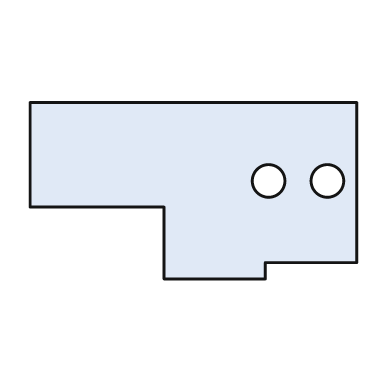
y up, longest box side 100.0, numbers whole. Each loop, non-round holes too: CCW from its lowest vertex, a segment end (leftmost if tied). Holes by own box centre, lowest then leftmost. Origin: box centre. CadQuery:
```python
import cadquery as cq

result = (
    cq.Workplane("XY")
    .moveTo(-9.0, -27.0)
    .lineTo(22.0, -27.0)
    .lineTo(22.0, -22.0)
    .lineTo(50.0, -22.0)
    .lineTo(50.0, 27.0)
    .lineTo(-50.0, 27.0)
    .lineTo(-50.0, -5.0)
    .lineTo(-9.0, -5.0)
    .close()
    .moveTo(23.0, 3.0)
    .circle(5.0)
    .moveTo(41.0, 3.0)
    .circle(5.0)
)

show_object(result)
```